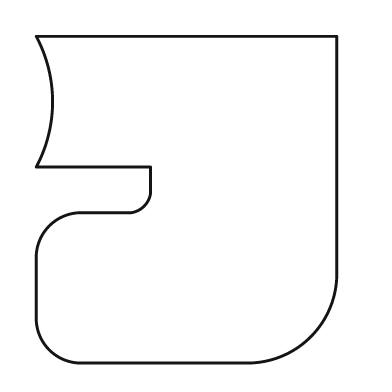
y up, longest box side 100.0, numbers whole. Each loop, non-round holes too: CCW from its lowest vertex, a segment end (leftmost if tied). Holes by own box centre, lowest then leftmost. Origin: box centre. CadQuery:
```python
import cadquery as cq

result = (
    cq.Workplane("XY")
    .moveTo(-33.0, -50.0)
    .lineTo(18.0, -50.0)
    .threePointArc((38.0, -42.0), (46.0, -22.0))
    .lineTo(46.0, 50.0)
    .lineTo(-46.0, 50.0)
    .threePointArc((-41.0, 30.0), (-46.0, 10.0))
    .lineTo(-11.0, 10.0)
    .lineTo(-11.0, 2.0)
    .threePointArc((-13.0, -2.0), (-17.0, -4.0))
    .lineTo(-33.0, -4.0)
    .threePointArc((-42.0, -8.0), (-46.0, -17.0))
    .lineTo(-46.0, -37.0)
    .threePointArc((-42.0, -46.0), (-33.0, -50.0))
    .close()
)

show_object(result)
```